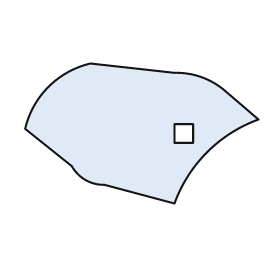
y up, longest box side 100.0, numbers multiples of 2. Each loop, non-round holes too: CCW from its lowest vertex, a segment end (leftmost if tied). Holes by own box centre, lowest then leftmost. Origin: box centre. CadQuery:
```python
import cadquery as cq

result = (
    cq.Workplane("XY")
    .moveTo(14.0, -30.0)
    .threePointArc((28.0, -8.0), (50.0, 6.0))
    .lineTo(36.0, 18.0)
    .threePointArc((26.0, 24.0), (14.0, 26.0))
    .lineTo(-22.0, 30.0)
    .threePointArc((-40.0, 20.0), (-50.0, 2.0))
    .lineTo(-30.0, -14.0)
    .threePointArc((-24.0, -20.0), (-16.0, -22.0))
    .close()
    .moveTo(14.0, -4.0)
    .lineTo(22.0, -4.0)
    .lineTo(22.0, 4.0)
    .lineTo(14.0, 4.0)
    .close()
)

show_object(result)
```